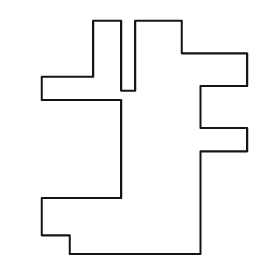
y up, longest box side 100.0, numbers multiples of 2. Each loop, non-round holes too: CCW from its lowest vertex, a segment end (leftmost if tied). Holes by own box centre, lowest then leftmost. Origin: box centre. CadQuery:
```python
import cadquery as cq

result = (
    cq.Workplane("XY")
    .moveTo(-32.0, -50.0)
    .lineTo(24.0, -50.0)
    .lineTo(24.0, -6.0)
    .lineTo(44.0, -6.0)
    .lineTo(44.0, 4.0)
    .lineTo(24.0, 4.0)
    .lineTo(24.0, 22.0)
    .lineTo(44.0, 22.0)
    .lineTo(44.0, 36.0)
    .lineTo(16.0, 36.0)
    .lineTo(16.0, 50.0)
    .lineTo(-4.0, 50.0)
    .lineTo(-4.0, 20.0)
    .lineTo(-10.0, 20.0)
    .lineTo(-10.0, 50.0)
    .lineTo(-22.0, 50.0)
    .lineTo(-22.0, 26.0)
    .lineTo(-44.0, 26.0)
    .lineTo(-44.0, 16.0)
    .lineTo(-10.0, 16.0)
    .lineTo(-10.0, -26.0)
    .lineTo(-44.0, -26.0)
    .lineTo(-44.0, -42.0)
    .lineTo(-32.0, -42.0)
    .close()
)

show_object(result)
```